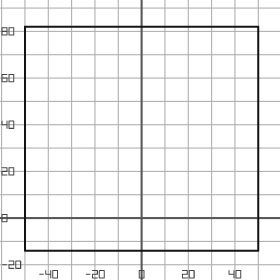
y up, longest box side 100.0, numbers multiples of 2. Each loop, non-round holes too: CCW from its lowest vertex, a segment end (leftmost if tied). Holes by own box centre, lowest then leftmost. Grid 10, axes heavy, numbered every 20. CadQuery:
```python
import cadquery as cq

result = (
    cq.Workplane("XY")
    .moveTo(-50.0, -14.0)
    .lineTo(50.0, -14.0)
    .lineTo(50.0, 82.0)
    .lineTo(-50.0, 82.0)
    .close()
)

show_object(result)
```